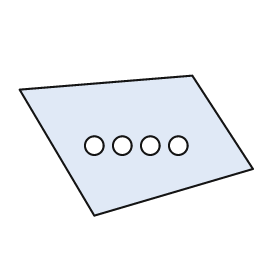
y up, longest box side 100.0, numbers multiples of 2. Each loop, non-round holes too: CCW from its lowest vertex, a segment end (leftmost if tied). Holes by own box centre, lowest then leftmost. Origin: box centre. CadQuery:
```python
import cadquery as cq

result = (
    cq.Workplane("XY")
    .moveTo(-18.0, -30.0)
    .lineTo(50.0, -10.0)
    .lineTo(24.0, 30.0)
    .lineTo(-50.0, 24.0)
    .close()
    .moveTo(-18.0, 0.0)
    .circle(4.0)
    .moveTo(-6.0, 0.0)
    .circle(4.0)
    .moveTo(6.0, 0.0)
    .circle(4.0)
    .moveTo(18.0, 0.0)
    .circle(4.0)
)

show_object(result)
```